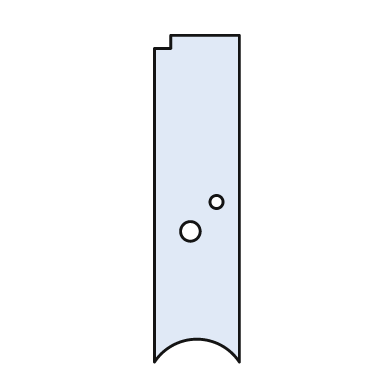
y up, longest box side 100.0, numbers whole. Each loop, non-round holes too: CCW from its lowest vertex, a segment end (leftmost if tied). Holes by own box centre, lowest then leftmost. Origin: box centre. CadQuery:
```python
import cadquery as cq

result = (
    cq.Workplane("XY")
    .moveTo(-13.0, -50.0)
    .threePointArc((0.0, -43.0), (13.0, -50.0))
    .lineTo(13.0, 50.0)
    .lineTo(-8.0, 50.0)
    .lineTo(-8.0, 46.0)
    .lineTo(-13.0, 46.0)
    .close()
    .moveTo(-2.0, -10.0)
    .circle(3.0)
    .moveTo(6.0, -1.0)
    .circle(2.0)
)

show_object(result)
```